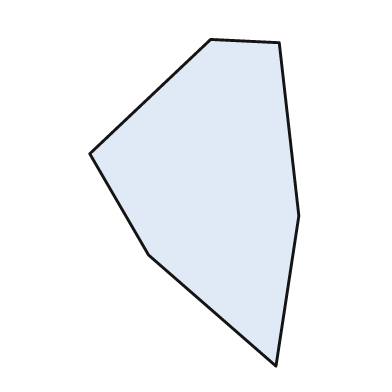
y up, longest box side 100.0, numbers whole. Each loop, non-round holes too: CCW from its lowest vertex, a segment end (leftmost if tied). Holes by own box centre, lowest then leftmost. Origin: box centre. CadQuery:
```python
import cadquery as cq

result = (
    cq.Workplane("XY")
    .moveTo(25.0, -50.0)
    .lineTo(32.0, -4.0)
    .lineTo(26.0, 49.0)
    .lineTo(5.0, 50.0)
    .lineTo(-32.0, 15.0)
    .lineTo(-14.0, -16.0)
    .close()
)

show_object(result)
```